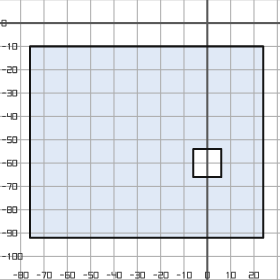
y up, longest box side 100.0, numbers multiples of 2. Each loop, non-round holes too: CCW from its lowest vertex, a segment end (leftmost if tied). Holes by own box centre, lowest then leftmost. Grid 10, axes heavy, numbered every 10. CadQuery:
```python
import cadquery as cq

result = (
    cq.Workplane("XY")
    .moveTo(-76.0, -92.0)
    .lineTo(24.0, -92.0)
    .lineTo(24.0, -10.0)
    .lineTo(-76.0, -10.0)
    .close()
    .moveTo(-6.0, -66.0)
    .lineTo(6.0, -66.0)
    .lineTo(6.0, -54.0)
    .lineTo(-6.0, -54.0)
    .close()
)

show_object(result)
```